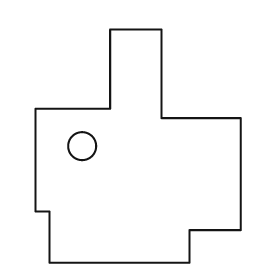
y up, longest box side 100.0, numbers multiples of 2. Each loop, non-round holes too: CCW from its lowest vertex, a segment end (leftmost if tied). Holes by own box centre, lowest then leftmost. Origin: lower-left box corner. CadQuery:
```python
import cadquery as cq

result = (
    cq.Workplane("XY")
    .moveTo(6.0, 0.0)
    .lineTo(66.0, 0.0)
    .lineTo(66.0, 14.0)
    .lineTo(88.0, 14.0)
    .lineTo(88.0, 62.0)
    .lineTo(54.0, 62.0)
    .lineTo(54.0, 100.0)
    .lineTo(32.0, 100.0)
    .lineTo(32.0, 66.0)
    .lineTo(0.0, 66.0)
    .lineTo(0.0, 22.0)
    .lineTo(6.0, 22.0)
    .close()
    .moveTo(20.0, 50.0)
    .circle(6.0)
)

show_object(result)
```